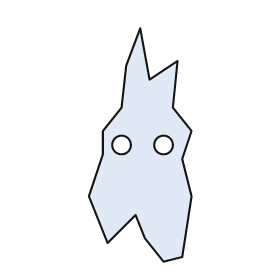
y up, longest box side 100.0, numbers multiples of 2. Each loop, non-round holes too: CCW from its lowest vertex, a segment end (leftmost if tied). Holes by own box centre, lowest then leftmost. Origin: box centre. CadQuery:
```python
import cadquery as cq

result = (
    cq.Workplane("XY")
    .moveTo(10.0, -50.0)
    .lineTo(18.0, -48.0)
    .lineTo(22.0, -22.0)
    .lineTo(18.0, -6.0)
    .lineTo(22.0, 6.0)
    .lineTo(14.0, 16.0)
    .lineTo(16.0, 36.0)
    .lineTo(4.0, 28.0)
    .lineTo(0.0, 50.0)
    .lineTo(-6.0, 34.0)
    .lineTo(-8.0, 16.0)
    .lineTo(-16.0, 6.0)
    .lineTo(-16.0, -4.0)
    .lineTo(-22.0, -22.0)
    .lineTo(-14.0, -42.0)
    .lineTo(-2.0, -30.0)
    .lineTo(2.0, -40.0)
    .close()
    .moveTo(-8.0, 0.0)
    .circle(4.0)
    .moveTo(10.0, 0.0)
    .circle(4.0)
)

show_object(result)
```